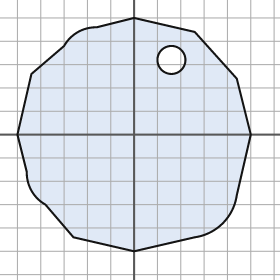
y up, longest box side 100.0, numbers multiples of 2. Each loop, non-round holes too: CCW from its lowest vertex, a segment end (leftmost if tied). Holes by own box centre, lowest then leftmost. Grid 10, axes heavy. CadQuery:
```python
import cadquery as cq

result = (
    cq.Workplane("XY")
    .moveTo(0.0, -50.0)
    .lineTo(26.0, -44.0)
    .threePointArc((38.0, -38.0), (44.0, -26.0))
    .lineTo(50.0, 0.0)
    .lineTo(44.0, 24.0)
    .lineTo(26.0, 44.0)
    .lineTo(0.0, 50.0)
    .lineTo(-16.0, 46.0)
    .threePointArc((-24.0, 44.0), (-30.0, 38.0))
    .lineTo(-44.0, 26.0)
    .lineTo(-50.0, 0.0)
    .lineTo(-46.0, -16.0)
    .threePointArc((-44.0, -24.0), (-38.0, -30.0))
    .lineTo(-26.0, -44.0)
    .close()
    .moveTo(16.0, 32.0)
    .circle(6.0)
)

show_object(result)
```